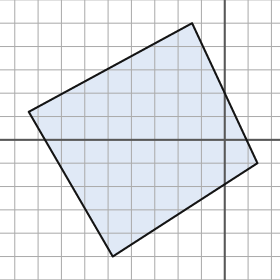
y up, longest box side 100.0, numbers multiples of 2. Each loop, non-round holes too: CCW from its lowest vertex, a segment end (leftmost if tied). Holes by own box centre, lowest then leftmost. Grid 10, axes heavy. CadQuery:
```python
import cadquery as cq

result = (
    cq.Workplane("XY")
    .moveTo(-48.0, -50.0)
    .lineTo(14.0, -10.0)
    .lineTo(-14.0, 50.0)
    .lineTo(-84.0, 12.0)
    .close()
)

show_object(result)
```